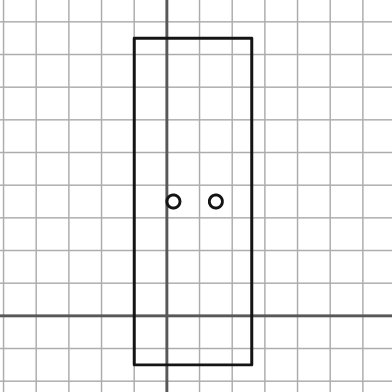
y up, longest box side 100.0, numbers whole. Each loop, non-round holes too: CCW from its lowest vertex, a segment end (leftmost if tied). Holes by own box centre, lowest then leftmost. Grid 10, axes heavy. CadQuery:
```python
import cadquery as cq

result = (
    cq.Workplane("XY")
    .moveTo(-10.0, -15.0)
    .lineTo(26.0, -15.0)
    .lineTo(26.0, 85.0)
    .lineTo(-10.0, 85.0)
    .close()
    .moveTo(2.0, 35.0)
    .circle(2.0)
    .moveTo(15.0, 35.0)
    .circle(2.0)
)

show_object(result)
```